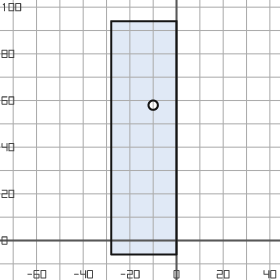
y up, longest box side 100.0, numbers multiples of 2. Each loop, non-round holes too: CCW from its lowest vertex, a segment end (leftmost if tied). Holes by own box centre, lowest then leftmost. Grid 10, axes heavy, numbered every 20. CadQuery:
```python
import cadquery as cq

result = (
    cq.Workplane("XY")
    .moveTo(-28.0, -6.0)
    .lineTo(0.0, -6.0)
    .lineTo(0.0, 94.0)
    .lineTo(-28.0, 94.0)
    .close()
    .moveTo(-10.0, 58.0)
    .circle(2.0)
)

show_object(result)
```